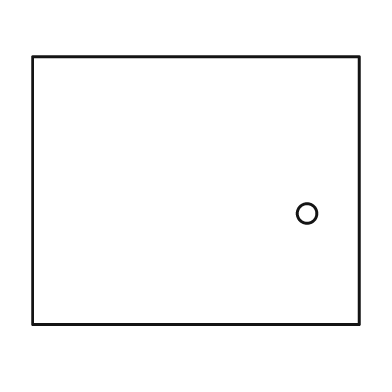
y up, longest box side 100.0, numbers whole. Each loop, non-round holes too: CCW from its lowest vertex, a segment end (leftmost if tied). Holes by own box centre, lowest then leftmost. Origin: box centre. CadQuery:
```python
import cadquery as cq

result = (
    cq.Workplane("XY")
    .moveTo(-50.0, -41.0)
    .lineTo(50.0, -41.0)
    .lineTo(50.0, 41.0)
    .lineTo(-50.0, 41.0)
    .close()
    .moveTo(34.0, -7.0)
    .circle(3.0)
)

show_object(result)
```